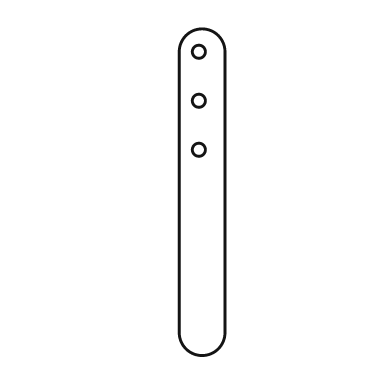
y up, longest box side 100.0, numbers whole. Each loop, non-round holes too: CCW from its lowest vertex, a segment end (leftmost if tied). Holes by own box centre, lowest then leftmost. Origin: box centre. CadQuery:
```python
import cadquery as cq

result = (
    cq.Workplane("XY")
    .moveTo(-7.0, -43.0)
    .threePointArc((0.0, -50.0), (7.0, -43.0))
    .lineTo(7.0, 43.0)
    .threePointArc((0.0, 50.0), (-7.0, 43.0))
    .close()
    .moveTo(-1.0, 13.0)
    .circle(2.0)
    .moveTo(-1.0, 28.0)
    .circle(2.0)
    .moveTo(-1.0, 43.0)
    .circle(2.0)
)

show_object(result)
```